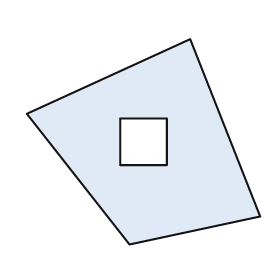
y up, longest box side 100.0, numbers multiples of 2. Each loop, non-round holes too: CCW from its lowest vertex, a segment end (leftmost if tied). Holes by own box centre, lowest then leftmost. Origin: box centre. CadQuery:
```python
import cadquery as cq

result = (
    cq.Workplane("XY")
    .moveTo(-6.0, -44.0)
    .lineTo(50.0, -32.0)
    .lineTo(20.0, 44.0)
    .lineTo(-50.0, 12.0)
    .close()
    .moveTo(-10.0, -10.0)
    .lineTo(10.0, -10.0)
    .lineTo(10.0, 10.0)
    .lineTo(-10.0, 10.0)
    .close()
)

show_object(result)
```